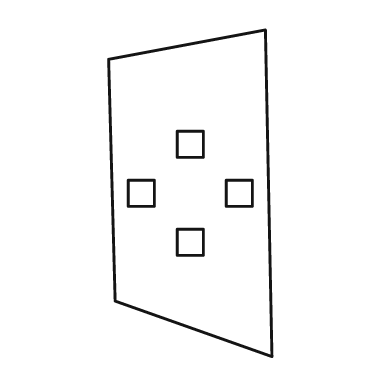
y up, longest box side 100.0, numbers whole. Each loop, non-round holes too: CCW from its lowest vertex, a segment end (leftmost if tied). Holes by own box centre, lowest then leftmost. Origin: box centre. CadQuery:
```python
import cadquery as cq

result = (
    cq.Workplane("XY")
    .moveTo(25.0, -50.0)
    .lineTo(23.0, 50.0)
    .lineTo(-25.0, 41.0)
    .lineTo(-23.0, -33.0)
    .close()
    .moveTo(-4.0, -19.0)
    .lineTo(4.0, -19.0)
    .lineTo(4.0, -11.0)
    .lineTo(-4.0, -11.0)
    .close()
    .moveTo(-19.0, -4.0)
    .lineTo(-11.0, -4.0)
    .lineTo(-11.0, 4.0)
    .lineTo(-19.0, 4.0)
    .close()
    .moveTo(11.0, -4.0)
    .lineTo(19.0, -4.0)
    .lineTo(19.0, 4.0)
    .lineTo(11.0, 4.0)
    .close()
    .moveTo(-4.0, 11.0)
    .lineTo(4.0, 11.0)
    .lineTo(4.0, 19.0)
    .lineTo(-4.0, 19.0)
    .close()
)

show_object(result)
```